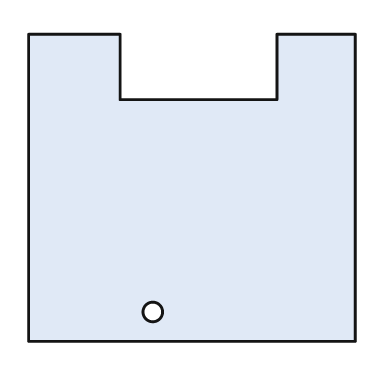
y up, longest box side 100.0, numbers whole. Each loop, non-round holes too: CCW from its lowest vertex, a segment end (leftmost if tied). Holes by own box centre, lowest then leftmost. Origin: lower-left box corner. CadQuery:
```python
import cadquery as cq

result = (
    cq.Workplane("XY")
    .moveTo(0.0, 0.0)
    .lineTo(100.0, 0.0)
    .lineTo(100.0, 94.0)
    .lineTo(76.0, 94.0)
    .lineTo(76.0, 74.0)
    .lineTo(28.0, 74.0)
    .lineTo(28.0, 94.0)
    .lineTo(0.0, 94.0)
    .close()
    .moveTo(38.0, 9.0)
    .circle(3.0)
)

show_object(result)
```